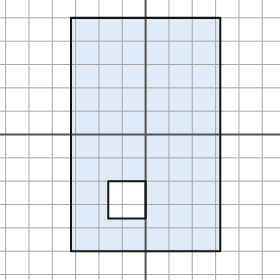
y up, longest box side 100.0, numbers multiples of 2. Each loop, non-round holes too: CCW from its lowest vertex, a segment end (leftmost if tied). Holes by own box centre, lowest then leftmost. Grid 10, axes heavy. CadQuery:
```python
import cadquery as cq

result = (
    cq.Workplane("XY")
    .moveTo(-32.0, -50.0)
    .lineTo(32.0, -50.0)
    .lineTo(32.0, 50.0)
    .lineTo(-32.0, 50.0)
    .close()
    .moveTo(-16.0, -36.0)
    .lineTo(0.0, -36.0)
    .lineTo(0.0, -20.0)
    .lineTo(-16.0, -20.0)
    .close()
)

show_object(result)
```